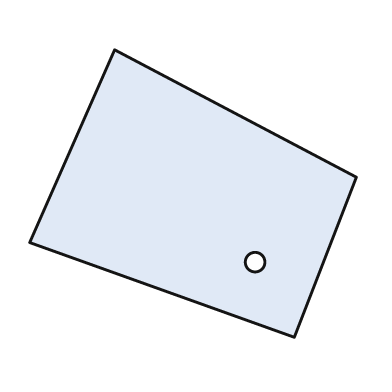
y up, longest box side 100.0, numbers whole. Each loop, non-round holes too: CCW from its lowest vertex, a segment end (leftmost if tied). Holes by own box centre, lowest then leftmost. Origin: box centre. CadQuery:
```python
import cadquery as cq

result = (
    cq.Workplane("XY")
    .moveTo(31.0, -44.0)
    .lineTo(50.0, 5.0)
    .lineTo(-24.0, 44.0)
    .lineTo(-50.0, -15.0)
    .close()
    .moveTo(19.0, -21.0)
    .circle(3.0)
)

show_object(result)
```